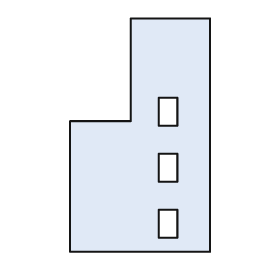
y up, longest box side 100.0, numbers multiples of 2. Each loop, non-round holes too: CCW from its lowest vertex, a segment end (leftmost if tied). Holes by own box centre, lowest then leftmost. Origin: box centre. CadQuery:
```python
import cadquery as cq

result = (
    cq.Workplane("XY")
    .moveTo(-30.0, -50.0)
    .lineTo(30.0, -50.0)
    .lineTo(30.0, 50.0)
    .lineTo(-4.0, 50.0)
    .lineTo(-4.0, 6.0)
    .lineTo(-30.0, 6.0)
    .close()
    .moveTo(8.0, -44.0)
    .lineTo(16.0, -44.0)
    .lineTo(16.0, -32.0)
    .lineTo(8.0, -32.0)
    .close()
    .moveTo(8.0, -20.0)
    .lineTo(16.0, -20.0)
    .lineTo(16.0, -8.0)
    .lineTo(8.0, -8.0)
    .close()
    .moveTo(8.0, 4.0)
    .lineTo(16.0, 4.0)
    .lineTo(16.0, 16.0)
    .lineTo(8.0, 16.0)
    .close()
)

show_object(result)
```